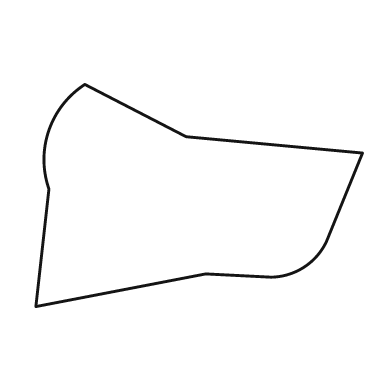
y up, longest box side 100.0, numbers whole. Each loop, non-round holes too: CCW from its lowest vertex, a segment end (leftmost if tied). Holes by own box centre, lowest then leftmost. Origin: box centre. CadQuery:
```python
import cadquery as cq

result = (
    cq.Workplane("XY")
    .moveTo(-50.0, -34.0)
    .lineTo(2.0, -24.0)
    .lineTo(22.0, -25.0)
    .threePointArc((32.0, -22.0), (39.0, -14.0))
    .lineTo(50.0, 13.0)
    .lineTo(-4.0, 18.0)
    .lineTo(-35.0, 34.0)
    .threePointArc((-46.0, 20.0), (-46.0, 2.0))
    .close()
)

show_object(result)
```